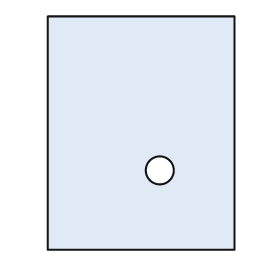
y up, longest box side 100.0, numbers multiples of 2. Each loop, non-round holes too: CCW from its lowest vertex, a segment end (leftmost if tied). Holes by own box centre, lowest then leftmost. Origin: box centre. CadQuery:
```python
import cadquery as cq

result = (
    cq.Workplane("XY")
    .moveTo(-40.0, -50.0)
    .lineTo(40.0, -50.0)
    .lineTo(40.0, 50.0)
    .lineTo(-40.0, 50.0)
    .close()
    .moveTo(8.0, -16.0)
    .circle(6.0)
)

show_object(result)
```